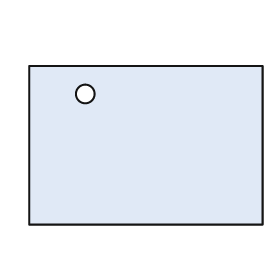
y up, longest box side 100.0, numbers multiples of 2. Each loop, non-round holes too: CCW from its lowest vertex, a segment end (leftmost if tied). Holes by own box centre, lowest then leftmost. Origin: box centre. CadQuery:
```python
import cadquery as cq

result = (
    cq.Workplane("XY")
    .moveTo(-50.0, -34.0)
    .lineTo(50.0, -34.0)
    .lineTo(50.0, 34.0)
    .lineTo(-50.0, 34.0)
    .close()
    .moveTo(-26.0, 22.0)
    .circle(4.0)
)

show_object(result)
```